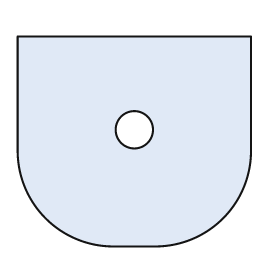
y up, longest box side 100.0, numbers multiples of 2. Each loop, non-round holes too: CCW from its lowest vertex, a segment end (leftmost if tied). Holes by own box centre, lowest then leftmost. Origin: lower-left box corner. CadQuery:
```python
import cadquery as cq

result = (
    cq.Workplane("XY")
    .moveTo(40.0, 0.0)
    .lineTo(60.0, 0.0)
    .threePointArc((88.0, 12.0), (100.0, 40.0))
    .lineTo(100.0, 90.0)
    .lineTo(0.0, 90.0)
    .lineTo(0.0, 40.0)
    .threePointArc((12.0, 12.0), (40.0, 0.0))
    .close()
    .moveTo(50.0, 50.0)
    .circle(8.0)
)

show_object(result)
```